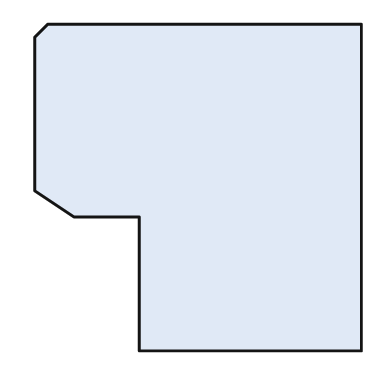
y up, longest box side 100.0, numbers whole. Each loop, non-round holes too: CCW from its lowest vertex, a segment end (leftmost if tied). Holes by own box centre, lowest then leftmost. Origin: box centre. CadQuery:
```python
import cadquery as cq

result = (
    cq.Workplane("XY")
    .moveTo(-18.0, -50.0)
    .lineTo(50.0, -50.0)
    .lineTo(50.0, 50.0)
    .lineTo(-46.0, 50.0)
    .lineTo(-50.0, 46.0)
    .lineTo(-50.0, -1.0)
    .lineTo(-38.0, -9.0)
    .lineTo(-18.0, -9.0)
    .close()
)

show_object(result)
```